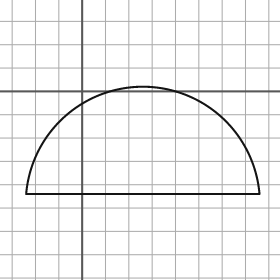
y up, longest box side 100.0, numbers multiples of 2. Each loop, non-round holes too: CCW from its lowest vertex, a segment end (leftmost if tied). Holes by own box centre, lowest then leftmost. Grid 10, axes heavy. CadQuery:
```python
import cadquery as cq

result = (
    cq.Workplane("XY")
    .moveTo(-24.0, -44.0)
    .lineTo(76.0, -44.0)
    .threePointArc((26.0, 2.0), (-24.0, -44.0))
    .close()
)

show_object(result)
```